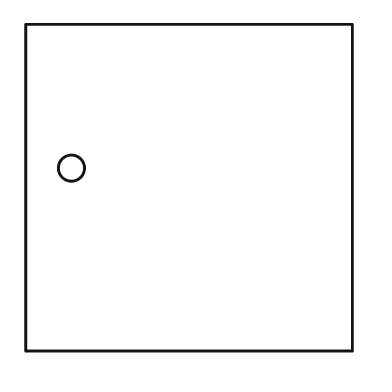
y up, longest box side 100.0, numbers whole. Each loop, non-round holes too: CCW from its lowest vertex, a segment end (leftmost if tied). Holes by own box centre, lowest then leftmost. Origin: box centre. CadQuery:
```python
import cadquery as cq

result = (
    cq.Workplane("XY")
    .moveTo(-50.0, -50.0)
    .lineTo(50.0, -50.0)
    .lineTo(50.0, 50.0)
    .lineTo(-50.0, 50.0)
    .close()
    .moveTo(-36.0, 6.0)
    .circle(4.0)
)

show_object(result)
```